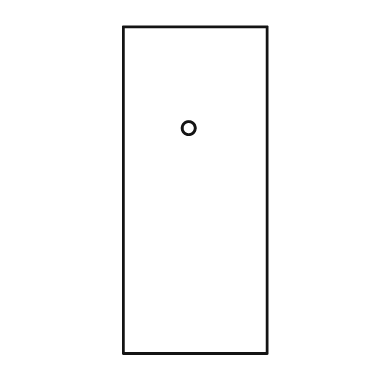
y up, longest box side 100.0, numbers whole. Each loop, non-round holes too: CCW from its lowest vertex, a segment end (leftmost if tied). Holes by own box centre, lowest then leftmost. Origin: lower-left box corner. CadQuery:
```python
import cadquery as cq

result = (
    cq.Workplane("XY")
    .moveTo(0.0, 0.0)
    .lineTo(44.0, 0.0)
    .lineTo(44.0, 100.0)
    .lineTo(0.0, 100.0)
    .close()
    .moveTo(20.0, 69.0)
    .circle(2.0)
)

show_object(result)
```